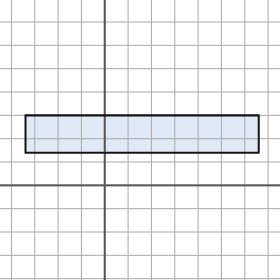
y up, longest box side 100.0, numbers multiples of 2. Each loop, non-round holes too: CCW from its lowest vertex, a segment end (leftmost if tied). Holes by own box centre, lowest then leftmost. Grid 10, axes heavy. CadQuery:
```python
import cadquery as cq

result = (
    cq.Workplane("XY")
    .moveTo(-34.0, 14.0)
    .lineTo(66.0, 14.0)
    .lineTo(66.0, 30.0)
    .lineTo(-34.0, 30.0)
    .close()
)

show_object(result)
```